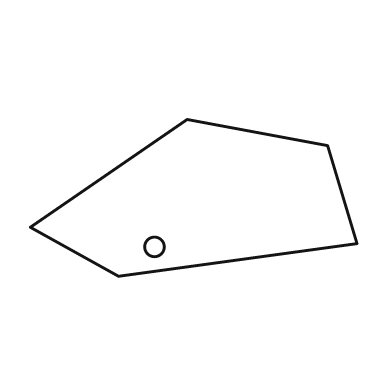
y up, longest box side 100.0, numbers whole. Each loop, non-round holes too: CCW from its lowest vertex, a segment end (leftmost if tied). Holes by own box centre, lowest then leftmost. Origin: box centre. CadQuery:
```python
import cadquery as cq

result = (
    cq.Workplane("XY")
    .moveTo(-23.0, -24.0)
    .lineTo(50.0, -14.0)
    .lineTo(41.0, 16.0)
    .lineTo(-2.0, 24.0)
    .lineTo(-50.0, -9.0)
    .close()
    .moveTo(-12.0, -15.0)
    .circle(3.0)
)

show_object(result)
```